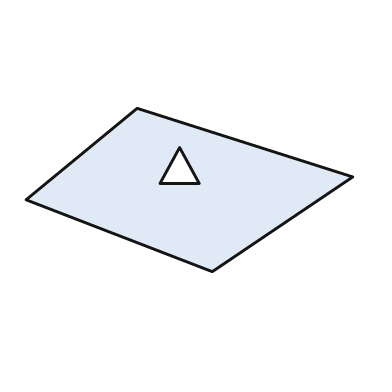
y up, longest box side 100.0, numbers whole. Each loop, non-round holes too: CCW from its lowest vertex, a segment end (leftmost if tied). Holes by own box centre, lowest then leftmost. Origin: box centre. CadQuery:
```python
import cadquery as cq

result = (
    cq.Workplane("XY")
    .moveTo(7.0, -25.0)
    .lineTo(50.0, 4.0)
    .lineTo(-16.0, 25.0)
    .lineTo(-50.0, -3.0)
    .close()
    .moveTo(-9.0, 2.0)
    .lineTo(3.0, 2.0)
    .lineTo(-3.0, 13.0)
    .close()
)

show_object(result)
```